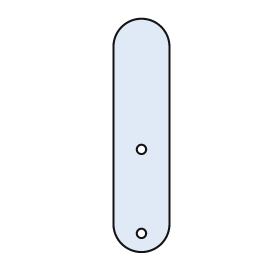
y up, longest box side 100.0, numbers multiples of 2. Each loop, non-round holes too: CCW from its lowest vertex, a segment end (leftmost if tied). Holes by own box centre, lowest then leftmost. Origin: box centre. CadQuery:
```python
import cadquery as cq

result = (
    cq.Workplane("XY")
    .moveTo(-12.0, -38.0)
    .threePointArc((0.0, -50.0), (12.0, -38.0))
    .lineTo(12.0, 38.0)
    .threePointArc((0.0, 50.0), (-12.0, 38.0))
    .close()
    .moveTo(0.0, -42.0)
    .circle(2.0)
    .moveTo(0.0, -6.0)
    .circle(2.0)
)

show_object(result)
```